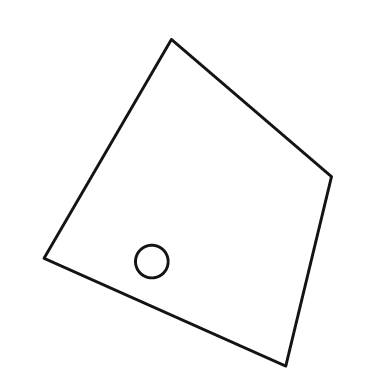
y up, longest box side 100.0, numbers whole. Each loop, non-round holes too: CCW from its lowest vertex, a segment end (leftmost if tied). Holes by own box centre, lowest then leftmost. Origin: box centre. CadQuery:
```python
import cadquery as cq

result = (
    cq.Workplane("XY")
    .moveTo(30.0, -50.0)
    .lineTo(44.0, 8.0)
    .lineTo(-5.0, 50.0)
    .lineTo(-44.0, -17.0)
    .close()
    .moveTo(-11.0, -18.0)
    .circle(5.0)
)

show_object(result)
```